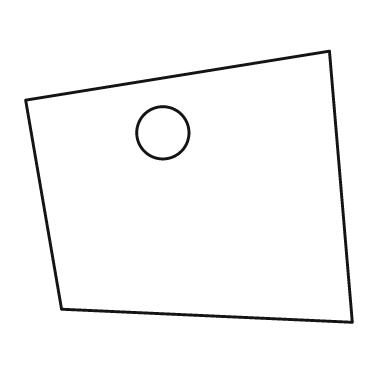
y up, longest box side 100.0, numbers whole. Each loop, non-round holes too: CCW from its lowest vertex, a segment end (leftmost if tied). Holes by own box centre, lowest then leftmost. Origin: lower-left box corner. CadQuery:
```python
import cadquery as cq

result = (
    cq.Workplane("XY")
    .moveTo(100.0, 0.0)
    .lineTo(93.0, 83.0)
    .lineTo(0.0, 68.0)
    .lineTo(11.0, 4.0)
    .close()
    .moveTo(42.0, 58.0)
    .circle(8.0)
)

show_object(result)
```